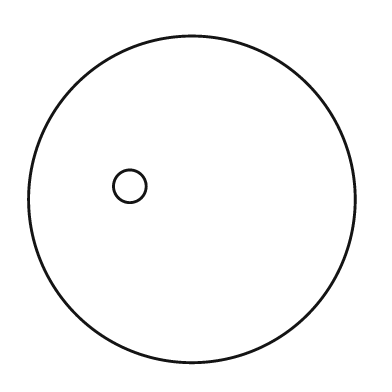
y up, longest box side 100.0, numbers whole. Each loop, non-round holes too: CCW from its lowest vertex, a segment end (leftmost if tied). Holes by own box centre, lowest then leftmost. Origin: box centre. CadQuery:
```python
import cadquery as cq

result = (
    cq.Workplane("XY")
    .moveTo(0.0, 0.0)
    .circle(50.0)
    .moveTo(-19.0, 4.0)
    .circle(5.0)
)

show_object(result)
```